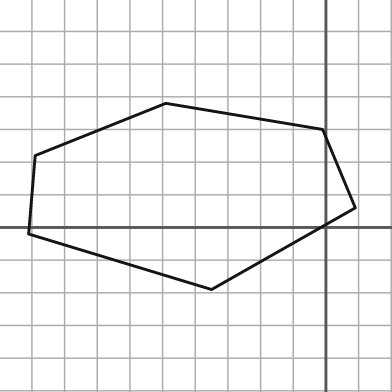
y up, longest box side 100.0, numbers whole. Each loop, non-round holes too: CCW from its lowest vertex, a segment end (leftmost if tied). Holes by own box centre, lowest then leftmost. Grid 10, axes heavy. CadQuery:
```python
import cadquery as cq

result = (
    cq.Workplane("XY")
    .moveTo(-35.0, -19.0)
    .lineTo(9.0, 6.0)
    .lineTo(-1.0, 30.0)
    .lineTo(-49.0, 38.0)
    .lineTo(-89.0, 22.0)
    .lineTo(-91.0, -2.0)
    .close()
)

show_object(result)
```